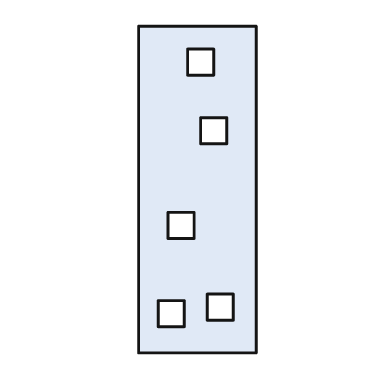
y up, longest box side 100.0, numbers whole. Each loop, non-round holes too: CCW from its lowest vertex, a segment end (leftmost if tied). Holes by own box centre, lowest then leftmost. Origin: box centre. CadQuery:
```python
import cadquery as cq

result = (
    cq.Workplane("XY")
    .moveTo(-18.0, -50.0)
    .lineTo(18.0, -50.0)
    .lineTo(18.0, 50.0)
    .lineTo(-18.0, 50.0)
    .close()
    .moveTo(-12.0, -42.0)
    .lineTo(-4.0, -42.0)
    .lineTo(-4.0, -34.0)
    .lineTo(-12.0, -34.0)
    .close()
    .moveTo(3.0, -40.0)
    .lineTo(11.0, -40.0)
    .lineTo(11.0, -32.0)
    .lineTo(3.0, -32.0)
    .close()
    .moveTo(-9.0, -15.0)
    .lineTo(-1.0, -15.0)
    .lineTo(-1.0, -7.0)
    .lineTo(-9.0, -7.0)
    .close()
    .moveTo(1.0, 14.0)
    .lineTo(9.0, 14.0)
    .lineTo(9.0, 22.0)
    .lineTo(1.0, 22.0)
    .close()
    .moveTo(-3.0, 35.0)
    .lineTo(5.0, 35.0)
    .lineTo(5.0, 43.0)
    .lineTo(-3.0, 43.0)
    .close()
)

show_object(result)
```